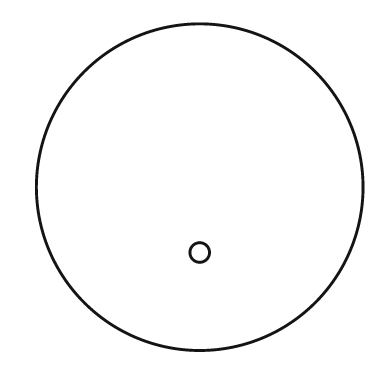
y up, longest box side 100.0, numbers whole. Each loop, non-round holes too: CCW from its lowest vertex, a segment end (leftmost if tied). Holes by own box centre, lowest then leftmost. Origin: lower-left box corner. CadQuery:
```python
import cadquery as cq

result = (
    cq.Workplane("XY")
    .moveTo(50.0, 50.0)
    .circle(50.0)
    .moveTo(50.0, 30.0)
    .circle(3.0)
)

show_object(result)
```